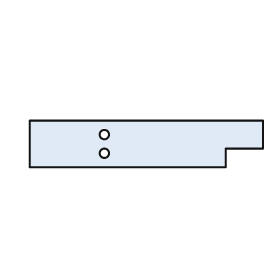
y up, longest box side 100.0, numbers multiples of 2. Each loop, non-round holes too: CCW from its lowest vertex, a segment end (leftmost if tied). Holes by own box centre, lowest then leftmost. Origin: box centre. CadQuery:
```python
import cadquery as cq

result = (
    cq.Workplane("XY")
    .moveTo(-50.0, -10.0)
    .lineTo(34.0, -10.0)
    .lineTo(34.0, -2.0)
    .lineTo(50.0, -2.0)
    .lineTo(50.0, 10.0)
    .lineTo(-50.0, 10.0)
    .close()
    .moveTo(-18.0, -4.0)
    .circle(2.0)
    .moveTo(-18.0, 4.0)
    .circle(2.0)
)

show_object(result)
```